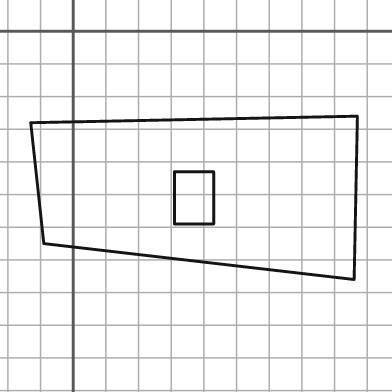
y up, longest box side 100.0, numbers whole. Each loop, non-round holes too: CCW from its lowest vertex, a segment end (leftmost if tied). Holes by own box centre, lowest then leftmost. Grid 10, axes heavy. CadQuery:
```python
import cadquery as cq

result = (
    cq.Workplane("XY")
    .moveTo(86.0, -76.0)
    .lineTo(87.0, -26.0)
    .lineTo(-13.0, -28.0)
    .lineTo(-9.0, -65.0)
    .close()
    .moveTo(31.0, -59.0)
    .lineTo(43.0, -59.0)
    .lineTo(43.0, -43.0)
    .lineTo(31.0, -43.0)
    .close()
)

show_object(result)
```